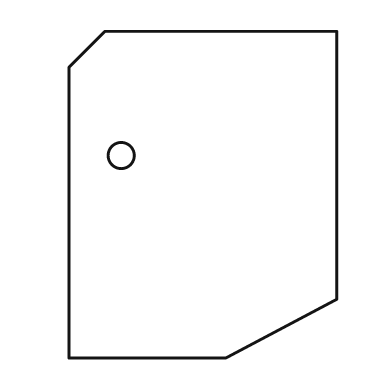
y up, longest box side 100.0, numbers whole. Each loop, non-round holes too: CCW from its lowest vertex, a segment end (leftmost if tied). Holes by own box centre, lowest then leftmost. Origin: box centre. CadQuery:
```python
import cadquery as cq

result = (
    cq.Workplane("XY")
    .moveTo(-41.0, -50.0)
    .lineTo(7.0, -50.0)
    .lineTo(41.0, -32.0)
    .lineTo(41.0, 50.0)
    .lineTo(-30.0, 50.0)
    .lineTo(-41.0, 39.0)
    .close()
    .moveTo(-25.0, 12.0)
    .circle(4.0)
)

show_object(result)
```